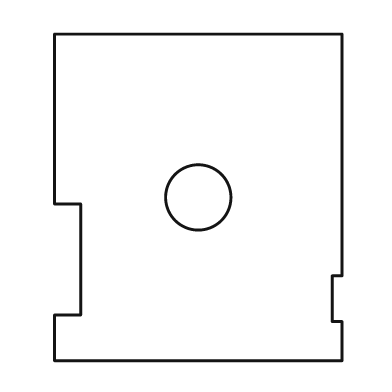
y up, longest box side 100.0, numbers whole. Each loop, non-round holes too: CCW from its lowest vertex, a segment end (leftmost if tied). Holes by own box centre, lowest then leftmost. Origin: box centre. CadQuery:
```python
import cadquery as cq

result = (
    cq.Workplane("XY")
    .moveTo(-44.0, -50.0)
    .lineTo(44.0, -50.0)
    .lineTo(44.0, -38.0)
    .lineTo(41.0, -38.0)
    .lineTo(41.0, -24.0)
    .lineTo(44.0, -24.0)
    .lineTo(44.0, 50.0)
    .lineTo(-44.0, 50.0)
    .lineTo(-44.0, -2.0)
    .lineTo(-36.0, -2.0)
    .lineTo(-36.0, -36.0)
    .lineTo(-44.0, -36.0)
    .close()
    .moveTo(0.0, 0.0)
    .circle(10.0)
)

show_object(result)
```